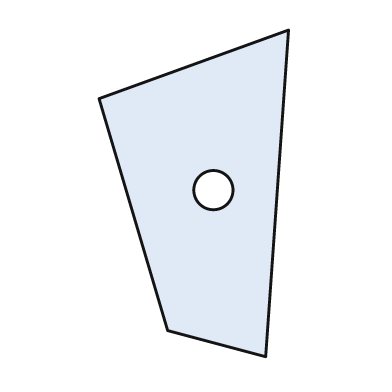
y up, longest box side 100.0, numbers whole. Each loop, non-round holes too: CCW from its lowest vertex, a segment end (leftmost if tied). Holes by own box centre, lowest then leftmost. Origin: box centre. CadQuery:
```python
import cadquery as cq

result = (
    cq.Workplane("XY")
    .moveTo(22.0, -50.0)
    .lineTo(29.0, 50.0)
    .lineTo(-29.0, 29.0)
    .lineTo(-8.0, -42.0)
    .close()
    .moveTo(6.0, 1.0)
    .circle(6.0)
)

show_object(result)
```